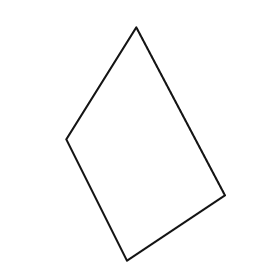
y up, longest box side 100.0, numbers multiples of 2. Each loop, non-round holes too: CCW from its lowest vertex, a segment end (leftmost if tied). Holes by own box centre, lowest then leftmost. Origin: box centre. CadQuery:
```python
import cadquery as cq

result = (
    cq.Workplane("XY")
    .moveTo(-8.0, -50.0)
    .lineTo(34.0, -22.0)
    .lineTo(-4.0, 50.0)
    .lineTo(-34.0, 2.0)
    .close()
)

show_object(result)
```